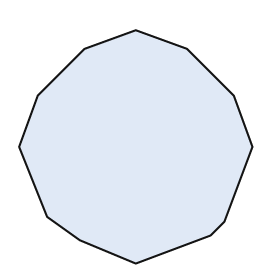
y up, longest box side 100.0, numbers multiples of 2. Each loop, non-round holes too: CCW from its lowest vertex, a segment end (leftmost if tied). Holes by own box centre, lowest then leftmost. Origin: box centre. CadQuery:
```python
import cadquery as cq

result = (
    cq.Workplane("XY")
    .moveTo(0.0, -50.0)
    .lineTo(32.0, -38.0)
    .lineTo(38.0, -32.0)
    .lineTo(50.0, 0.0)
    .lineTo(42.0, 22.0)
    .lineTo(22.0, 42.0)
    .lineTo(0.0, 50.0)
    .lineTo(-22.0, 42.0)
    .lineTo(-42.0, 22.0)
    .lineTo(-50.0, 0.0)
    .lineTo(-38.0, -30.0)
    .lineTo(-24.0, -40.0)
    .close()
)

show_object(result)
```